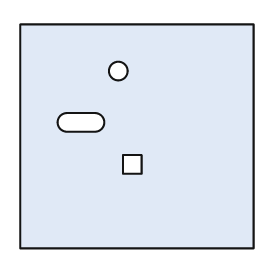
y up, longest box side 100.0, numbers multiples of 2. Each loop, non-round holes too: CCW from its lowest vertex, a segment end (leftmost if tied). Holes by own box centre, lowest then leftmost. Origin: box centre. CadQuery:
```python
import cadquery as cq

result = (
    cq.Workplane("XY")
    .moveTo(-50.0, -48.0)
    .lineTo(50.0, -48.0)
    .lineTo(50.0, 48.0)
    .lineTo(-50.0, 48.0)
    .close()
    .moveTo(-6.0, -16.0)
    .lineTo(2.0, -16.0)
    .lineTo(2.0, -8.0)
    .lineTo(-6.0, -8.0)
    .close()
    .moveTo(-30.0, 2.0)
    .lineTo(-18.0, 2.0)
    .threePointArc((-14.0, 6.0), (-18.0, 10.0))
    .lineTo(-30.0, 10.0)
    .threePointArc((-34.0, 6.0), (-30.0, 2.0))
    .close()
    .moveTo(-8.0, 28.0)
    .circle(4.0)
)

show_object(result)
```